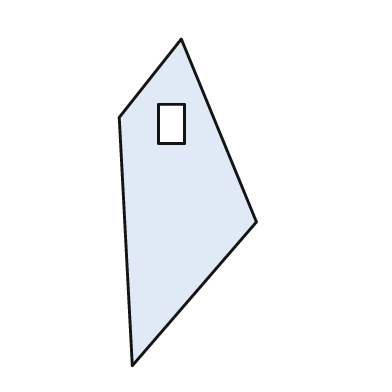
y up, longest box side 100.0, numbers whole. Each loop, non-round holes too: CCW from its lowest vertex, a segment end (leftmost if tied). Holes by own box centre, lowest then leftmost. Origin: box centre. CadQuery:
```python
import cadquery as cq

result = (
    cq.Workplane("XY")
    .moveTo(-17.0, -50.0)
    .lineTo(21.0, -6.0)
    .lineTo(-2.0, 50.0)
    .lineTo(-21.0, 26.0)
    .close()
    .moveTo(-9.0, 18.0)
    .lineTo(-1.0, 18.0)
    .lineTo(-1.0, 30.0)
    .lineTo(-9.0, 30.0)
    .close()
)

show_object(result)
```